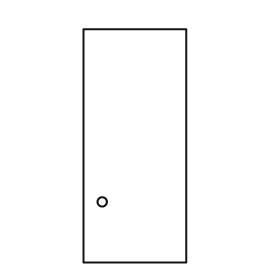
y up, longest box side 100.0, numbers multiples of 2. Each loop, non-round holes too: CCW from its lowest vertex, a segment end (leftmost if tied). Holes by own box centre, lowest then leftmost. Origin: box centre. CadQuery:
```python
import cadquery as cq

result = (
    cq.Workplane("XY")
    .moveTo(-22.0, -50.0)
    .lineTo(22.0, -50.0)
    .lineTo(22.0, 50.0)
    .lineTo(-22.0, 50.0)
    .close()
    .moveTo(-14.0, -24.0)
    .circle(2.0)
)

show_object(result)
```